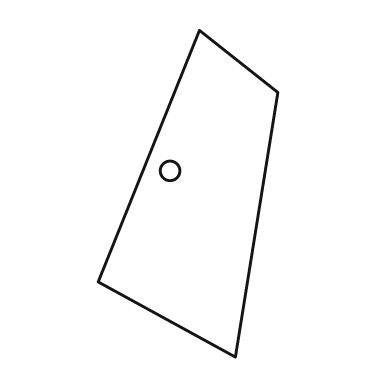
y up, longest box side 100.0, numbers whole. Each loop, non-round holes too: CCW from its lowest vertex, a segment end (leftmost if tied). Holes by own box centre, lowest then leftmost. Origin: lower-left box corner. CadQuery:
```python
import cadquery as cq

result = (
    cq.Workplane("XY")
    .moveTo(42.0, 0.0)
    .lineTo(55.0, 81.0)
    .lineTo(31.0, 100.0)
    .lineTo(0.0, 23.0)
    .close()
    .moveTo(22.0, 57.0)
    .circle(3.0)
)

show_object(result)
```